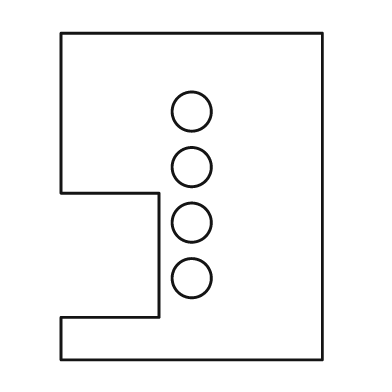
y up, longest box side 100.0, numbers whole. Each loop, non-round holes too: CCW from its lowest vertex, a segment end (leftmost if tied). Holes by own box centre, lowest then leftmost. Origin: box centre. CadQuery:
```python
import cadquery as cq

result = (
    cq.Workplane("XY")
    .moveTo(-40.0, -50.0)
    .lineTo(40.0, -50.0)
    .lineTo(40.0, 50.0)
    .lineTo(-40.0, 50.0)
    .lineTo(-40.0, 1.0)
    .lineTo(-10.0, 1.0)
    .lineTo(-10.0, -37.0)
    .lineTo(-40.0, -37.0)
    .close()
    .moveTo(0.0, -25.0)
    .circle(6.0)
    .moveTo(0.0, -8.0)
    .circle(6.0)
    .moveTo(0.0, 9.0)
    .circle(6.0)
    .moveTo(0.0, 26.0)
    .circle(6.0)
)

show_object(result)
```